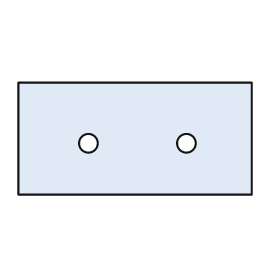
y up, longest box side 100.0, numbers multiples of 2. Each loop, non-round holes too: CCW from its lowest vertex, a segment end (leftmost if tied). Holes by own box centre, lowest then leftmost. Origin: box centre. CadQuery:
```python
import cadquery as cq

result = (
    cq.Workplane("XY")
    .moveTo(-50.0, -24.0)
    .lineTo(50.0, -24.0)
    .lineTo(50.0, 24.0)
    .lineTo(-50.0, 24.0)
    .close()
    .moveTo(-20.0, -2.0)
    .circle(4.0)
    .moveTo(22.0, -2.0)
    .circle(4.0)
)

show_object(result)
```